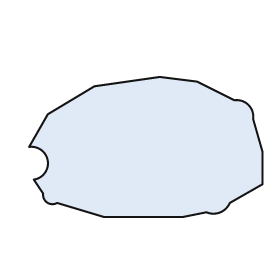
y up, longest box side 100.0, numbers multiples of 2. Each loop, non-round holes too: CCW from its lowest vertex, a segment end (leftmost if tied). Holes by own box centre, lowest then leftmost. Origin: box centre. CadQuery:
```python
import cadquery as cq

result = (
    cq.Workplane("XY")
    .moveTo(-18.0, -30.0)
    .lineTo(16.0, -30.0)
    .lineTo(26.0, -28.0)
    .threePointArc((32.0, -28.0), (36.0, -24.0))
    .lineTo(50.0, -16.0)
    .lineTo(50.0, -2.0)
    .lineTo(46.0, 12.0)
    .threePointArc((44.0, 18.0), (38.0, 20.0))
    .lineTo(22.0, 28.0)
    .lineTo(6.0, 30.0)
    .lineTo(-22.0, 26.0)
    .lineTo(-42.0, 14.0)
    .lineTo(-50.0, 0.0)
    .threePointArc((-42.0, -6.0), (-48.0, -14.0))
    .lineTo(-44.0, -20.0)
    .threePointArc((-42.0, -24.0), (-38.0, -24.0))
    .close()
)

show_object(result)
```